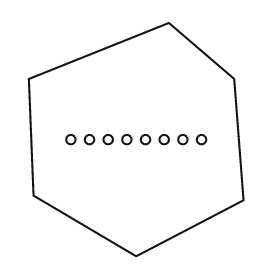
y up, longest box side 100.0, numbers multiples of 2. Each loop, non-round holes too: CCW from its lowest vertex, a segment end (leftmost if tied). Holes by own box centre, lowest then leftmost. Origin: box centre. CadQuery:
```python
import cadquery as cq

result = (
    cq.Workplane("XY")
    .moveTo(0.0, -50.0)
    .lineTo(46.0, -26.0)
    .lineTo(42.0, 26.0)
    .lineTo(14.0, 50.0)
    .lineTo(-46.0, 26.0)
    .lineTo(-44.0, -24.0)
    .close()
    .moveTo(-28.0, 0.0)
    .circle(2.0)
    .moveTo(-20.0, 0.0)
    .circle(2.0)
    .moveTo(-12.0, 0.0)
    .circle(2.0)
    .moveTo(-4.0, 0.0)
    .circle(2.0)
    .moveTo(4.0, 0.0)
    .circle(2.0)
    .moveTo(12.0, 0.0)
    .circle(2.0)
    .moveTo(20.0, 0.0)
    .circle(2.0)
    .moveTo(28.0, 0.0)
    .circle(2.0)
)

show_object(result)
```